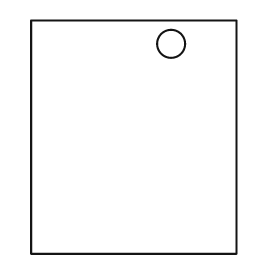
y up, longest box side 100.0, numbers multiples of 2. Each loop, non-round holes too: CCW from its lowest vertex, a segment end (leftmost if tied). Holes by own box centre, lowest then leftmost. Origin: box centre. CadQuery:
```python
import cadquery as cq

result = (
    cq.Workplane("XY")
    .moveTo(-44.0, -50.0)
    .lineTo(44.0, -50.0)
    .lineTo(44.0, 50.0)
    .lineTo(-44.0, 50.0)
    .close()
    .moveTo(16.0, 40.0)
    .circle(6.0)
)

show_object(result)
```